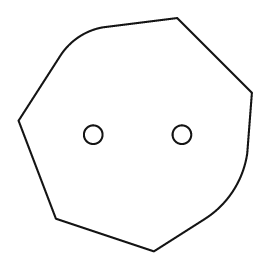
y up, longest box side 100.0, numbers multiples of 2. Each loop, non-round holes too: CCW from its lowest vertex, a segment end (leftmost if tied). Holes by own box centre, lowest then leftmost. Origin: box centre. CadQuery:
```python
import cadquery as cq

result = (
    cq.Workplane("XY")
    .moveTo(8.0, -50.0)
    .lineTo(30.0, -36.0)
    .threePointArc((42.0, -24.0), (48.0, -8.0))
    .lineTo(50.0, 18.0)
    .lineTo(18.0, 50.0)
    .lineTo(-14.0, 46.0)
    .threePointArc((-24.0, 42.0), (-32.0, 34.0))
    .lineTo(-50.0, 6.0)
    .lineTo(-34.0, -36.0)
    .close()
    .moveTo(-18.0, 0.0)
    .circle(4.0)
    .moveTo(20.0, 0.0)
    .circle(4.0)
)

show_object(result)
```